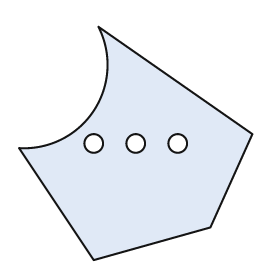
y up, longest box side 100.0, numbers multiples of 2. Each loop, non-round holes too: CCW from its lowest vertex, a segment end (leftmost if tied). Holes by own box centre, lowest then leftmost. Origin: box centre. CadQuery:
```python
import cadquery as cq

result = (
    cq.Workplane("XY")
    .moveTo(-18.0, -50.0)
    .lineTo(32.0, -36.0)
    .lineTo(50.0, 4.0)
    .lineTo(-16.0, 50.0)
    .threePointArc((-18.0, 14.0), (-50.0, -2.0))
    .close()
    .moveTo(-18.0, 0.0)
    .circle(4.0)
    .moveTo(0.0, 0.0)
    .circle(4.0)
    .moveTo(18.0, 0.0)
    .circle(4.0)
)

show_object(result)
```